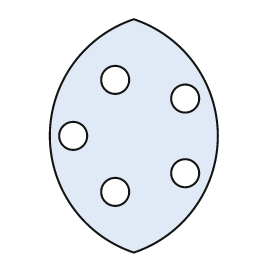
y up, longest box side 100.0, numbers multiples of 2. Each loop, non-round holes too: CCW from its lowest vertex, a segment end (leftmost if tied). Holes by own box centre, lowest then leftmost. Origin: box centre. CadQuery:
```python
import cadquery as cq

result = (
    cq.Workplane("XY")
    .moveTo(0.0, -50.0)
    .threePointArc((36.0, 0.0), (0.0, 50.0))
    .threePointArc((-36.0, 0.0), (0.0, -50.0))
    .close()
    .moveTo(-8.0, -24.0)
    .circle(6.0)
    .moveTo(22.0, -16.0)
    .circle(6.0)
    .moveTo(-26.0, 0.0)
    .circle(6.0)
    .moveTo(22.0, 16.0)
    .circle(6.0)
    .moveTo(-8.0, 24.0)
    .circle(6.0)
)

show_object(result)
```